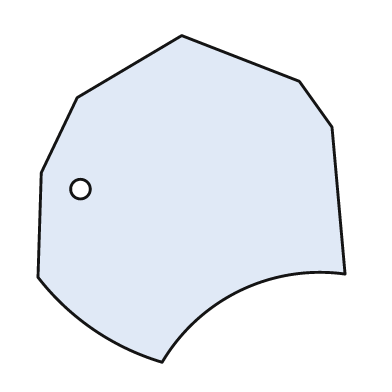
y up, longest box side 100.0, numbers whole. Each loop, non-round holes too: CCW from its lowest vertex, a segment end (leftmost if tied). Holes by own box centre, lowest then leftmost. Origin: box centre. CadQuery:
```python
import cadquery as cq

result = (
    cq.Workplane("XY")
    .moveTo(-9.0, -50.0)
    .threePointArc((15.0, -28.0), (47.0, -23.0))
    .lineTo(43.0, 22.0)
    .lineTo(33.0, 36.0)
    .lineTo(-3.0, 50.0)
    .lineTo(-35.0, 31.0)
    .lineTo(-46.0, 8.0)
    .lineTo(-47.0, -24.0)
    .threePointArc((-30.0, -40.0), (-9.0, -50.0))
    .close()
    .moveTo(-34.0, 3.0)
    .circle(3.0)
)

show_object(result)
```